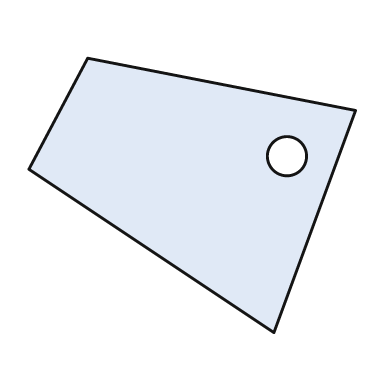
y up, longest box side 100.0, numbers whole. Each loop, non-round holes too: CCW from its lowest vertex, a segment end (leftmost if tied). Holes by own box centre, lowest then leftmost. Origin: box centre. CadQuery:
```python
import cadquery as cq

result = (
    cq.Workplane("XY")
    .moveTo(25.0, -42.0)
    .lineTo(50.0, 26.0)
    .lineTo(-32.0, 42.0)
    .lineTo(-50.0, 8.0)
    .close()
    .moveTo(29.0, 12.0)
    .circle(6.0)
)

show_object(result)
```